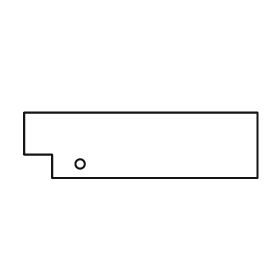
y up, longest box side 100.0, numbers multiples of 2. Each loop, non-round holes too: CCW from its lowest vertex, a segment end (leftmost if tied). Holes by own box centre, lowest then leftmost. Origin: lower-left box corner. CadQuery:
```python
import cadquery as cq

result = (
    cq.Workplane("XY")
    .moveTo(12.0, 0.0)
    .lineTo(100.0, 0.0)
    .lineTo(100.0, 28.0)
    .lineTo(0.0, 28.0)
    .lineTo(0.0, 10.0)
    .lineTo(12.0, 10.0)
    .close()
    .moveTo(24.0, 6.0)
    .circle(2.0)
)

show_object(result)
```